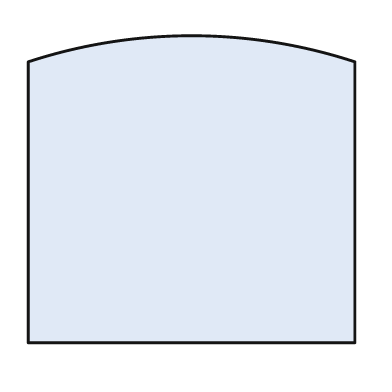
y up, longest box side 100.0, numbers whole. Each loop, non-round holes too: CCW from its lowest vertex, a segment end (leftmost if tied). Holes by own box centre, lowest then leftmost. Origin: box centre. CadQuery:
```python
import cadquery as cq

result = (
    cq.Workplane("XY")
    .moveTo(-50.0, -47.0)
    .lineTo(50.0, -47.0)
    .lineTo(50.0, 39.0)
    .threePointArc((0.0, 47.0), (-50.0, 39.0))
    .close()
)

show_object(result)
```